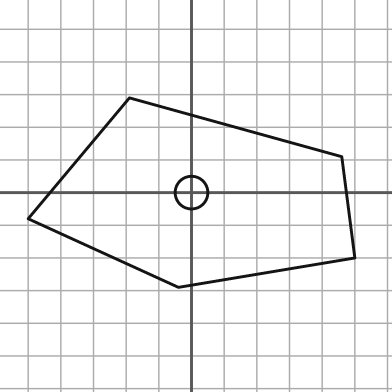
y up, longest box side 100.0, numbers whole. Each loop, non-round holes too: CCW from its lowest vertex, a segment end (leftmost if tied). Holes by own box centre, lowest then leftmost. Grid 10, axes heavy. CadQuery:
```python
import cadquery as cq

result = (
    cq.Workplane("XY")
    .moveTo(-4.0, -29.0)
    .lineTo(50.0, -20.0)
    .lineTo(46.0, 11.0)
    .lineTo(-19.0, 29.0)
    .lineTo(-50.0, -8.0)
    .close()
    .moveTo(0.0, 0.0)
    .circle(5.0)
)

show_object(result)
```